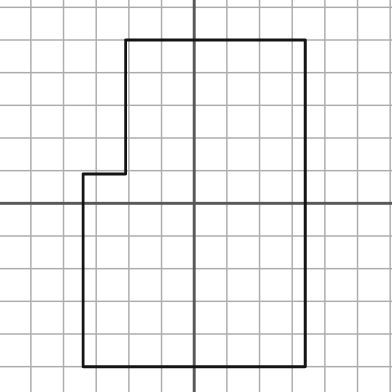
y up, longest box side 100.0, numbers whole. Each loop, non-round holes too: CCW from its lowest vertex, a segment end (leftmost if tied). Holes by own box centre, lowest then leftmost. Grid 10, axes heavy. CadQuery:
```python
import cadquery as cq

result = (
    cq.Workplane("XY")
    .moveTo(-34.0, -50.0)
    .lineTo(34.0, -50.0)
    .lineTo(34.0, 50.0)
    .lineTo(-21.0, 50.0)
    .lineTo(-21.0, 9.0)
    .lineTo(-34.0, 9.0)
    .close()
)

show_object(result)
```